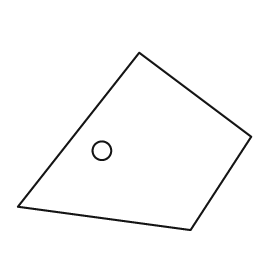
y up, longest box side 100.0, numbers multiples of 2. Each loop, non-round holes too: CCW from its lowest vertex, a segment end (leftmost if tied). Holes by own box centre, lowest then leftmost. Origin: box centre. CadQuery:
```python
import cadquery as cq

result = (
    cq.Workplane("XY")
    .moveTo(24.0, -38.0)
    .lineTo(50.0, 2.0)
    .lineTo(2.0, 38.0)
    .lineTo(-50.0, -28.0)
    .close()
    .moveTo(-14.0, -4.0)
    .circle(4.0)
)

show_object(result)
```